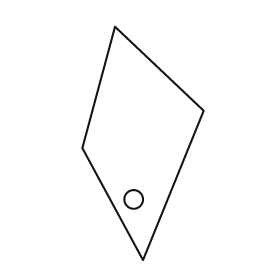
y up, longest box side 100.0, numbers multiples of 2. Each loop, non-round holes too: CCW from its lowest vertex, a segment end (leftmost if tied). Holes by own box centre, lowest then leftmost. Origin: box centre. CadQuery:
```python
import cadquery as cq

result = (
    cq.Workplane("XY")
    .moveTo(0.0, -50.0)
    .lineTo(26.0, 14.0)
    .lineTo(-12.0, 50.0)
    .lineTo(-26.0, -2.0)
    .close()
    .moveTo(-4.0, -24.0)
    .circle(4.0)
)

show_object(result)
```